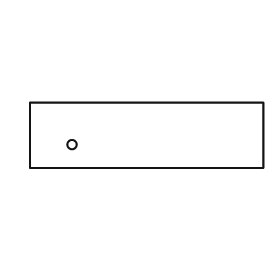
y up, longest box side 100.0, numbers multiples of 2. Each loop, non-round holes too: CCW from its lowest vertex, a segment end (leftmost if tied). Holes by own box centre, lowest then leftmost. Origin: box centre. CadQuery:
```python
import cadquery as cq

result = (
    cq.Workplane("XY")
    .moveTo(-50.0, -14.0)
    .lineTo(50.0, -14.0)
    .lineTo(50.0, 14.0)
    .lineTo(-50.0, 14.0)
    .close()
    .moveTo(-32.0, -4.0)
    .circle(2.0)
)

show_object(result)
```